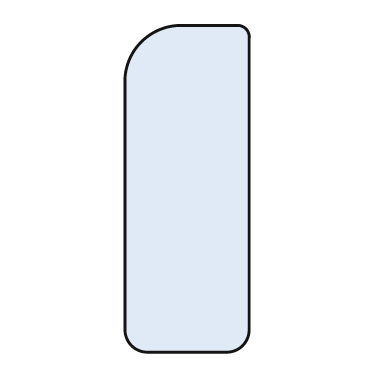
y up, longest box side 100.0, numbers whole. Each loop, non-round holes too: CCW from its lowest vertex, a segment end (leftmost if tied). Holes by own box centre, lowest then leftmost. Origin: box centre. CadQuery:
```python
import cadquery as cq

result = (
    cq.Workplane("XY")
    .moveTo(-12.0, -50.0)
    .lineTo(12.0, -50.0)
    .threePointArc((17.0, -48.0), (19.0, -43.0))
    .lineTo(19.0, 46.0)
    .threePointArc((18.0, 49.0), (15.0, 50.0))
    .lineTo(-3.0, 50.0)
    .threePointArc((-14.0, 45.0), (-19.0, 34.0))
    .lineTo(-19.0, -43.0)
    .threePointArc((-17.0, -48.0), (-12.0, -50.0))
    .close()
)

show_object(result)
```